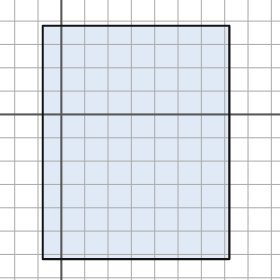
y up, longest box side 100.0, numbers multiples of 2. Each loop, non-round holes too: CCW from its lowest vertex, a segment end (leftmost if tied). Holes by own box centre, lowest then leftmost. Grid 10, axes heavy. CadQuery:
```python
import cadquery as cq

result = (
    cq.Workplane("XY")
    .moveTo(-8.0, -62.0)
    .lineTo(72.0, -62.0)
    .lineTo(72.0, 38.0)
    .lineTo(-8.0, 38.0)
    .close()
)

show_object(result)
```